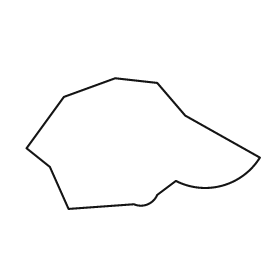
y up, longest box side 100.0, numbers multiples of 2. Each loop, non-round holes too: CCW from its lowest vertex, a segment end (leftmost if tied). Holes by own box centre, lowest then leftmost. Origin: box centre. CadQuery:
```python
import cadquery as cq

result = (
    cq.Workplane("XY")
    .moveTo(-32.0, -28.0)
    .lineTo(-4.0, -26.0)
    .threePointArc((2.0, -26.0), (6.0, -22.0))
    .lineTo(14.0, -16.0)
    .threePointArc((34.0, -18.0), (50.0, -6.0))
    .lineTo(18.0, 12.0)
    .lineTo(6.0, 26.0)
    .lineTo(-12.0, 28.0)
    .lineTo(-34.0, 20.0)
    .lineTo(-50.0, -2.0)
    .lineTo(-40.0, -10.0)
    .close()
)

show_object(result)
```